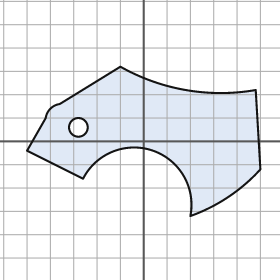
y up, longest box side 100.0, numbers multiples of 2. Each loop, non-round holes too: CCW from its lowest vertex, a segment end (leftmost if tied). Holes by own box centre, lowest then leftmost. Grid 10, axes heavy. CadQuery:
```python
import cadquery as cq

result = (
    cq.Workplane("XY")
    .moveTo(20.0, -32.0)
    .threePointArc((36.0, -24.0), (50.0, -12.0))
    .lineTo(48.0, 22.0)
    .threePointArc((18.0, 22.0), (-10.0, 32.0))
    .lineTo(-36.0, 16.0)
    .threePointArc((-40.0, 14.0), (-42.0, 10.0))
    .lineTo(-50.0, -4.0)
    .lineTo(-26.0, -16.0)
    .threePointArc((4.0, -4.0), (20.0, -32.0))
    .close()
    .moveTo(-28.0, 6.0)
    .circle(4.0)
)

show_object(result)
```